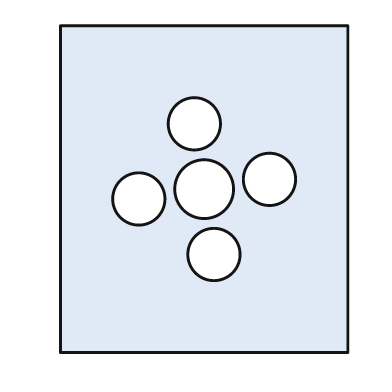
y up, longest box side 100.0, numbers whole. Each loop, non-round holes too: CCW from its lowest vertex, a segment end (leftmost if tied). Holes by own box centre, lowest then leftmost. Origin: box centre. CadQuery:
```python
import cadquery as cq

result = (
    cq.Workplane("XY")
    .moveTo(-44.0, -50.0)
    .lineTo(44.0, -50.0)
    .lineTo(44.0, 50.0)
    .lineTo(-44.0, 50.0)
    .close()
    .moveTo(3.0, -20.0)
    .circle(8.0)
    .moveTo(-20.0, -3.0)
    .circle(8.0)
    .moveTo(0.0, 0.0)
    .circle(9.0)
    .moveTo(20.0, 3.0)
    .circle(8.0)
    .moveTo(-3.0, 20.0)
    .circle(8.0)
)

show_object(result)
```